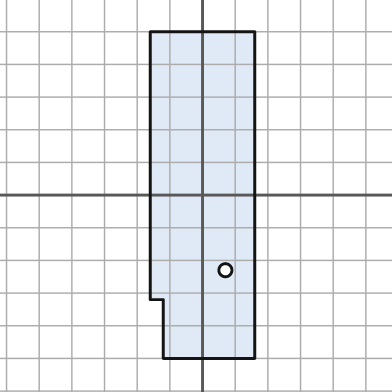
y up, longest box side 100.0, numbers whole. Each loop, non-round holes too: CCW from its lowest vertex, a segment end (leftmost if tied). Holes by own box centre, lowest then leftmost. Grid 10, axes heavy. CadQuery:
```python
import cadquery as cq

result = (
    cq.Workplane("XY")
    .moveTo(-12.0, -50.0)
    .lineTo(16.0, -50.0)
    .lineTo(16.0, 50.0)
    .lineTo(-16.0, 50.0)
    .lineTo(-16.0, -32.0)
    .lineTo(-12.0, -32.0)
    .close()
    .moveTo(7.0, -23.0)
    .circle(2.0)
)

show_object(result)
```